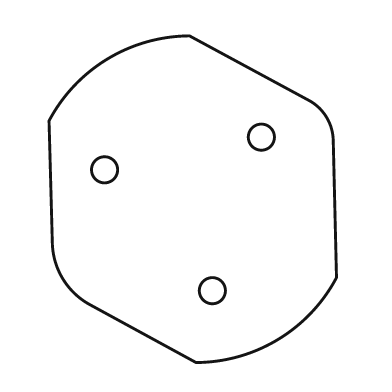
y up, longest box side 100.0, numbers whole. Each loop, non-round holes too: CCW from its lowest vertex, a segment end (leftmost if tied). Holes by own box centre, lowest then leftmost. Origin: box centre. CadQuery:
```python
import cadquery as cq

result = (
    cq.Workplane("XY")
    .moveTo(1.0, -50.0)
    .threePointArc((26.0, -43.0), (44.0, -24.0))
    .lineTo(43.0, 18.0)
    .threePointArc((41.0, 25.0), (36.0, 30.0))
    .lineTo(-1.0, 50.0)
    .threePointArc((-26.0, 43.0), (-44.0, 24.0))
    .lineTo(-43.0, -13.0)
    .threePointArc((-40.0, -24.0), (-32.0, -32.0))
    .close()
    .moveTo(6.0, -28.0)
    .circle(4.0)
    .moveTo(-27.0, 9.0)
    .circle(4.0)
    .moveTo(21.0, 19.0)
    .circle(4.0)
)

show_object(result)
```